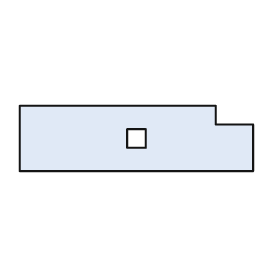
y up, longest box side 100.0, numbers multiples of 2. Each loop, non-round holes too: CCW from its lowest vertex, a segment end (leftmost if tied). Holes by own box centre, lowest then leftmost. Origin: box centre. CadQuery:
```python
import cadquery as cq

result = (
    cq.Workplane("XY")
    .moveTo(-50.0, -14.0)
    .lineTo(50.0, -14.0)
    .lineTo(50.0, 6.0)
    .lineTo(34.0, 6.0)
    .lineTo(34.0, 14.0)
    .lineTo(-50.0, 14.0)
    .close()
    .moveTo(-4.0, -4.0)
    .lineTo(4.0, -4.0)
    .lineTo(4.0, 4.0)
    .lineTo(-4.0, 4.0)
    .close()
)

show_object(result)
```